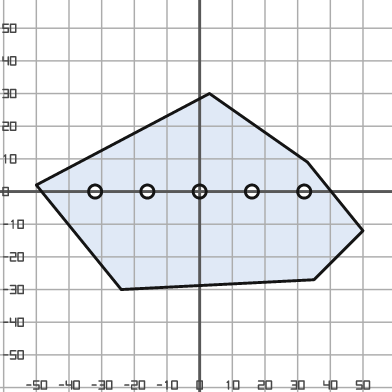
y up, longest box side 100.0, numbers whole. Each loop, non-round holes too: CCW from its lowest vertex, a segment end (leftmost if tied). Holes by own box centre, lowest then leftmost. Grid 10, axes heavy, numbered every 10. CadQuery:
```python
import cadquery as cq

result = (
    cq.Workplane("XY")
    .moveTo(-24.0, -30.0)
    .lineTo(35.0, -27.0)
    .lineTo(50.0, -12.0)
    .lineTo(33.0, 9.0)
    .lineTo(3.0, 30.0)
    .lineTo(-50.0, 2.0)
    .close()
    .moveTo(-32.0, 0.0)
    .circle(2.0)
    .moveTo(-16.0, 0.0)
    .circle(2.0)
    .moveTo(0.0, 0.0)
    .circle(2.0)
    .moveTo(16.0, 0.0)
    .circle(2.0)
    .moveTo(32.0, 0.0)
    .circle(2.0)
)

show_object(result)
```